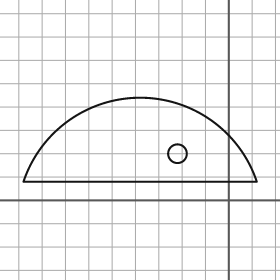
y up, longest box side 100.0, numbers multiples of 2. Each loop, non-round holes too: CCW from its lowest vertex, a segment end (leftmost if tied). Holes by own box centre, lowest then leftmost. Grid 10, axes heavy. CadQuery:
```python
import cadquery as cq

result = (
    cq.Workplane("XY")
    .moveTo(-88.0, 8.0)
    .lineTo(12.0, 8.0)
    .threePointArc((-38.0, 44.0), (-88.0, 8.0))
    .close()
    .moveTo(-22.0, 20.0)
    .circle(4.0)
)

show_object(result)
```